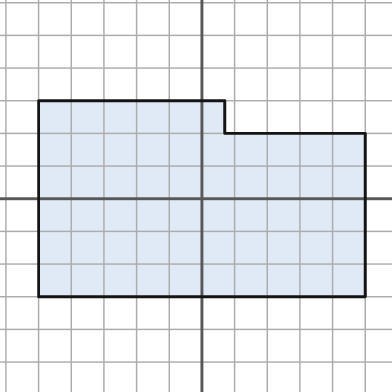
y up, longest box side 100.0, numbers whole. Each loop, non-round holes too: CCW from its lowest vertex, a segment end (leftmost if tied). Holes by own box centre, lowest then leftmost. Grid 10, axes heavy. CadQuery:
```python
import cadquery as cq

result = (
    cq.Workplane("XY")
    .moveTo(-50.0, -30.0)
    .lineTo(50.0, -30.0)
    .lineTo(50.0, 20.0)
    .lineTo(7.0, 20.0)
    .lineTo(7.0, 30.0)
    .lineTo(-50.0, 30.0)
    .close()
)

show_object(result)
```